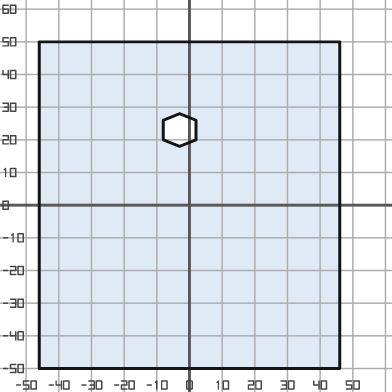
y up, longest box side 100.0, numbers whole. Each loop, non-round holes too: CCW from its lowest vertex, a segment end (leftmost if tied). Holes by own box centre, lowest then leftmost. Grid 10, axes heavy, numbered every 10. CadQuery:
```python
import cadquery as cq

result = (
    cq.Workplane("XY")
    .moveTo(-46.0, -50.0)
    .lineTo(46.0, -50.0)
    .lineTo(46.0, 50.0)
    .lineTo(-46.0, 50.0)
    .close()
    .moveTo(-3.0, 18.0)
    .lineTo(2.0, 20.0)
    .lineTo(2.0, 26.0)
    .lineTo(-3.0, 28.0)
    .lineTo(-8.0, 26.0)
    .lineTo(-8.0, 20.0)
    .close()
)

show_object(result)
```